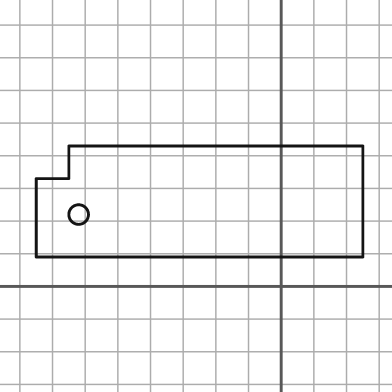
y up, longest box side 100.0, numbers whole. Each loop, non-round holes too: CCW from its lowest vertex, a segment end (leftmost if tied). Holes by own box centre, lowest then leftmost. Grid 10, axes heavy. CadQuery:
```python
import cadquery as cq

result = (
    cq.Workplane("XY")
    .moveTo(-75.0, 9.0)
    .lineTo(25.0, 9.0)
    .lineTo(25.0, 43.0)
    .lineTo(-65.0, 43.0)
    .lineTo(-65.0, 33.0)
    .lineTo(-75.0, 33.0)
    .close()
    .moveTo(-62.0, 22.0)
    .circle(3.0)
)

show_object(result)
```